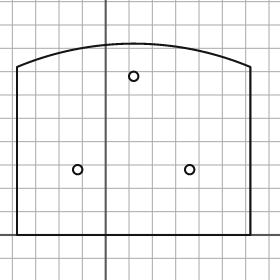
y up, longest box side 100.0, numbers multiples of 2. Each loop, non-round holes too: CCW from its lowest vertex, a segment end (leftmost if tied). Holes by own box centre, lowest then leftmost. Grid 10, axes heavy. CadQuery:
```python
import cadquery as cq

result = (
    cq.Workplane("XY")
    .moveTo(-38.0, 0.0)
    .lineTo(62.0, 0.0)
    .lineTo(62.0, 72.0)
    .threePointArc((12.0, 82.0), (-38.0, 72.0))
    .close()
    .moveTo(-12.0, 28.0)
    .circle(2.0)
    .moveTo(36.0, 28.0)
    .circle(2.0)
    .moveTo(12.0, 68.0)
    .circle(2.0)
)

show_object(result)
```